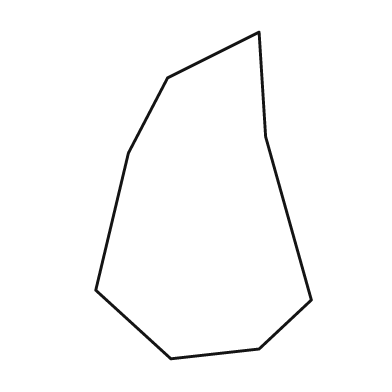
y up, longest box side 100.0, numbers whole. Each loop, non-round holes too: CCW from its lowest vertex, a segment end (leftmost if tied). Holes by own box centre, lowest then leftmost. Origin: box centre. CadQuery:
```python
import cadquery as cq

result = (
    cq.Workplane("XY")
    .moveTo(-10.0, -50.0)
    .lineTo(17.0, -47.0)
    .lineTo(33.0, -32.0)
    .lineTo(19.0, 18.0)
    .lineTo(17.0, 50.0)
    .lineTo(-11.0, 36.0)
    .lineTo(-23.0, 13.0)
    .lineTo(-33.0, -29.0)
    .close()
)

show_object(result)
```